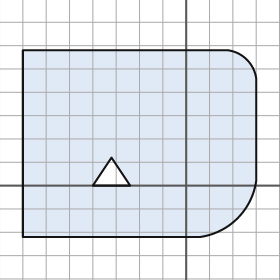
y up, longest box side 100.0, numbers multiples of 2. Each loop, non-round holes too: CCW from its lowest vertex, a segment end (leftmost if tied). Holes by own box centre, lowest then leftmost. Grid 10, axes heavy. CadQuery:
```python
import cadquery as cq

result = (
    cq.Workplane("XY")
    .moveTo(-70.0, -22.0)
    .lineTo(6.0, -22.0)
    .threePointArc((22.0, -14.0), (30.0, 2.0))
    .lineTo(30.0, 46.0)
    .threePointArc((26.0, 54.0), (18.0, 58.0))
    .lineTo(-70.0, 58.0)
    .close()
    .moveTo(-40.0, 0.0)
    .lineTo(-24.0, 0.0)
    .lineTo(-32.0, 12.0)
    .close()
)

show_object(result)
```